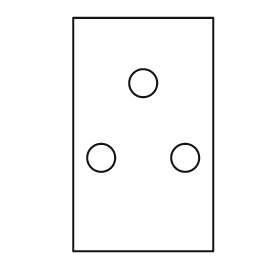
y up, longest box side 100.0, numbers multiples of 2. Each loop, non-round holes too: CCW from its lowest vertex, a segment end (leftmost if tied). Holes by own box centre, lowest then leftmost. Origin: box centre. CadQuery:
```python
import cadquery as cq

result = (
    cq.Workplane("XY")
    .moveTo(-30.0, -50.0)
    .lineTo(30.0, -50.0)
    .lineTo(30.0, 50.0)
    .lineTo(-30.0, 50.0)
    .close()
    .moveTo(-18.0, -10.0)
    .circle(6.0)
    .moveTo(18.0, -10.0)
    .circle(6.0)
    .moveTo(0.0, 22.0)
    .circle(6.0)
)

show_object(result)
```